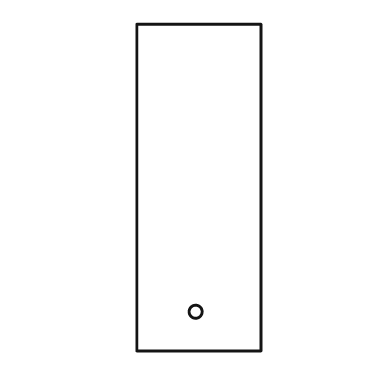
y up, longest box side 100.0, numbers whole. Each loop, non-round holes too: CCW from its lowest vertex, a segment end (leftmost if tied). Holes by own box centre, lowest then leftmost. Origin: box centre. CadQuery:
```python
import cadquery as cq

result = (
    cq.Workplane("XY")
    .moveTo(-19.0, -50.0)
    .lineTo(19.0, -50.0)
    .lineTo(19.0, 50.0)
    .lineTo(-19.0, 50.0)
    .close()
    .moveTo(-1.0, -38.0)
    .circle(2.0)
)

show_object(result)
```